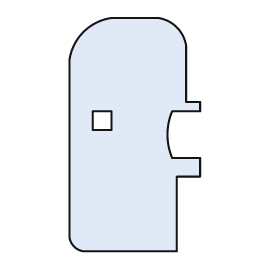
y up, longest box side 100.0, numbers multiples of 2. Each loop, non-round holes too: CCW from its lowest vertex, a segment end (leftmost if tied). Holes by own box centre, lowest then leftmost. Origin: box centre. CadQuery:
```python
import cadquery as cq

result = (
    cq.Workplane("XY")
    .moveTo(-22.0, -50.0)
    .lineTo(18.0, -50.0)
    .lineTo(18.0, -18.0)
    .lineTo(28.0, -18.0)
    .lineTo(28.0, -10.0)
    .lineTo(16.0, -10.0)
    .threePointArc((14.0, 0.0), (16.0, 10.0))
    .lineTo(28.0, 10.0)
    .lineTo(28.0, 14.0)
    .lineTo(22.0, 14.0)
    .lineTo(22.0, 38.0)
    .threePointArc((18.0, 46.0), (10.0, 50.0))
    .lineTo(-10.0, 50.0)
    .threePointArc((-22.0, 44.0), (-28.0, 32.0))
    .lineTo(-28.0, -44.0)
    .threePointArc((-26.0, -48.0), (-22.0, -50.0))
    .close()
    .moveTo(-18.0, 2.0)
    .lineTo(-10.0, 2.0)
    .lineTo(-10.0, 10.0)
    .lineTo(-18.0, 10.0)
    .close()
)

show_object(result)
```